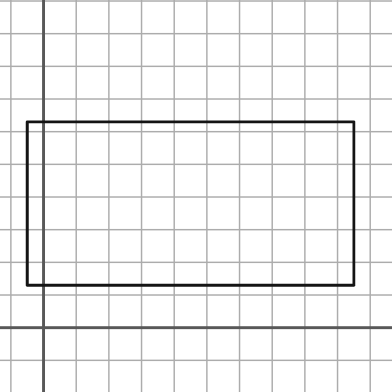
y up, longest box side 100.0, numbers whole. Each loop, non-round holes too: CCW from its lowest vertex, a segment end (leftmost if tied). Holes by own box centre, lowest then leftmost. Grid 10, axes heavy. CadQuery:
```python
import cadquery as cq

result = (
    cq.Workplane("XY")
    .moveTo(-5.0, 13.0)
    .lineTo(95.0, 13.0)
    .lineTo(95.0, 63.0)
    .lineTo(-5.0, 63.0)
    .close()
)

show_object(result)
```